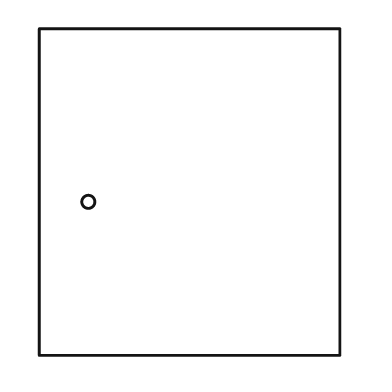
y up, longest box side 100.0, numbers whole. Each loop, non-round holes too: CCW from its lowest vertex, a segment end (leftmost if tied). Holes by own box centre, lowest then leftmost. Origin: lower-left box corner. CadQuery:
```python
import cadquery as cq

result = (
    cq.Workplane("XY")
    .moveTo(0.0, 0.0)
    .lineTo(92.0, 0.0)
    .lineTo(92.0, 100.0)
    .lineTo(0.0, 100.0)
    .close()
    .moveTo(15.0, 47.0)
    .circle(2.0)
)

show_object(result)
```